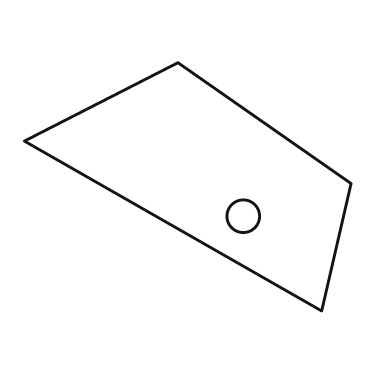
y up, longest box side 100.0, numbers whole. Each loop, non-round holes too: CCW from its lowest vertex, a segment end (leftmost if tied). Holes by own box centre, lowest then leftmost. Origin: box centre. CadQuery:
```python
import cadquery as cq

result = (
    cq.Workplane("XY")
    .moveTo(41.0, -38.0)
    .lineTo(50.0, 1.0)
    .lineTo(-3.0, 38.0)
    .lineTo(-50.0, 14.0)
    .close()
    .moveTo(17.0, -9.0)
    .circle(5.0)
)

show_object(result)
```